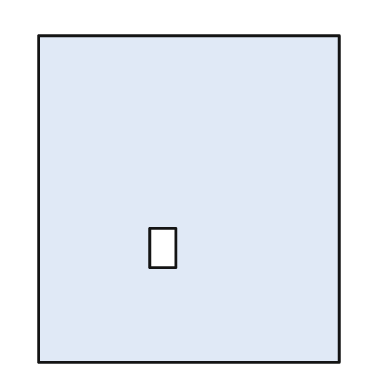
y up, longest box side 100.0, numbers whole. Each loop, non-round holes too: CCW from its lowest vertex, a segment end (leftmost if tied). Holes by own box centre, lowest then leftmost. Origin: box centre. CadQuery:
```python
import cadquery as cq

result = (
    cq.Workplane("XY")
    .moveTo(-46.0, -50.0)
    .lineTo(46.0, -50.0)
    .lineTo(46.0, 50.0)
    .lineTo(-46.0, 50.0)
    .close()
    .moveTo(-12.0, -21.0)
    .lineTo(-4.0, -21.0)
    .lineTo(-4.0, -9.0)
    .lineTo(-12.0, -9.0)
    .close()
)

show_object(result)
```